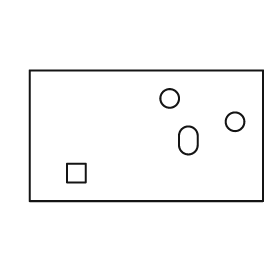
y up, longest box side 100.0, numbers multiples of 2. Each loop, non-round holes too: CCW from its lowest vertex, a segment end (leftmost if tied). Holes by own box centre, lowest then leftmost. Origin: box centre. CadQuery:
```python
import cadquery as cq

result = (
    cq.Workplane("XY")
    .moveTo(-50.0, -28.0)
    .lineTo(50.0, -28.0)
    .lineTo(50.0, 28.0)
    .lineTo(-50.0, 28.0)
    .close()
    .moveTo(-34.0, -20.0)
    .lineTo(-26.0, -20.0)
    .lineTo(-26.0, -12.0)
    .lineTo(-34.0, -12.0)
    .close()
    .moveTo(14.0, -4.0)
    .threePointArc((18.0, -8.0), (22.0, -4.0))
    .lineTo(22.0, 0.0)
    .threePointArc((18.0, 4.0), (14.0, 0.0))
    .close()
    .moveTo(38.0, 6.0)
    .circle(4.0)
    .moveTo(10.0, 16.0)
    .circle(4.0)
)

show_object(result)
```